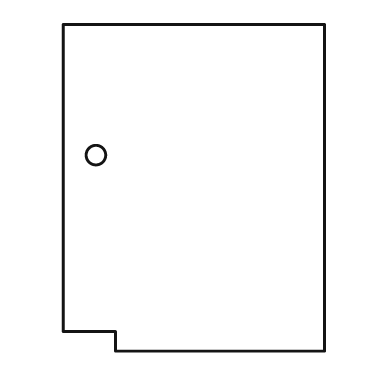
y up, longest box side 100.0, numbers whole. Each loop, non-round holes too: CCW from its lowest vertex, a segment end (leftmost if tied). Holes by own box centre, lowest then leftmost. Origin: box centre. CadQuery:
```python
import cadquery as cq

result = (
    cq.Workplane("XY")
    .moveTo(-24.0, -50.0)
    .lineTo(40.0, -50.0)
    .lineTo(40.0, 50.0)
    .lineTo(-40.0, 50.0)
    .lineTo(-40.0, -44.0)
    .lineTo(-24.0, -44.0)
    .close()
    .moveTo(-30.0, 10.0)
    .circle(3.0)
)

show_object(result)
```